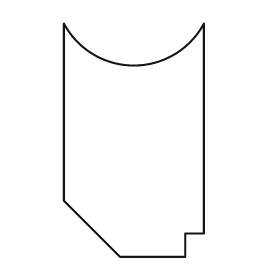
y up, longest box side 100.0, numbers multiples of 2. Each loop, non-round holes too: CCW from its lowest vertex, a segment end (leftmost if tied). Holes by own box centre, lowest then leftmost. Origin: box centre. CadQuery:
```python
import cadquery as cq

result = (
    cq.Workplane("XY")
    .moveTo(-6.0, -50.0)
    .lineTo(22.0, -50.0)
    .lineTo(22.0, -40.0)
    .lineTo(30.0, -40.0)
    .lineTo(30.0, 50.0)
    .threePointArc((0.0, 32.0), (-30.0, 50.0))
    .lineTo(-30.0, -26.0)
    .close()
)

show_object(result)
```